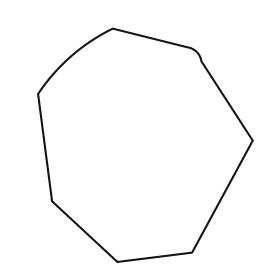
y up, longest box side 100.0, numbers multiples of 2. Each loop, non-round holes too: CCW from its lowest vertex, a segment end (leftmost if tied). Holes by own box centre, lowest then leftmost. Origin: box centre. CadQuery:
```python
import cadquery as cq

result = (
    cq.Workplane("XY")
    .moveTo(-12.0, -50.0)
    .lineTo(20.0, -46.0)
    .lineTo(46.0, 2.0)
    .lineTo(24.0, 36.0)
    .threePointArc((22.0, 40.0), (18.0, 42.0))
    .lineTo(-14.0, 50.0)
    .threePointArc((-32.0, 38.0), (-46.0, 22.0))
    .lineTo(-40.0, -24.0)
    .close()
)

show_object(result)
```